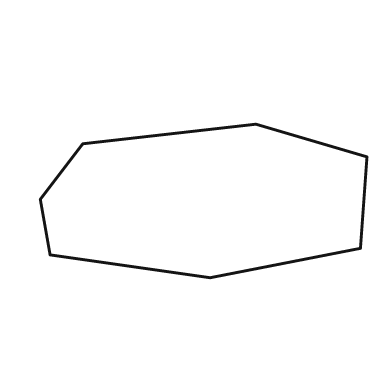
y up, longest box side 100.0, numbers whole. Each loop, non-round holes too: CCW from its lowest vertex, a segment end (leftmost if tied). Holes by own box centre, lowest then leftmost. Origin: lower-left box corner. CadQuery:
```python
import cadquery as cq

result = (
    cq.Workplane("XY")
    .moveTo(52.0, 0.0)
    .lineTo(98.0, 9.0)
    .lineTo(100.0, 37.0)
    .lineTo(66.0, 47.0)
    .lineTo(13.0, 41.0)
    .lineTo(0.0, 24.0)
    .lineTo(3.0, 7.0)
    .close()
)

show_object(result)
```